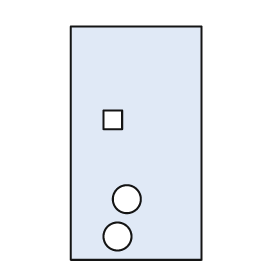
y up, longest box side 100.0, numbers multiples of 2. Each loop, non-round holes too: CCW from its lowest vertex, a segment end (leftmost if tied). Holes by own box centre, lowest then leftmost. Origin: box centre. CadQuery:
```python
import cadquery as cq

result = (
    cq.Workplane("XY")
    .moveTo(-28.0, -50.0)
    .lineTo(28.0, -50.0)
    .lineTo(28.0, 50.0)
    .lineTo(-28.0, 50.0)
    .close()
    .moveTo(-8.0, -40.0)
    .circle(6.0)
    .moveTo(-4.0, -24.0)
    .circle(6.0)
    .moveTo(-14.0, 6.0)
    .lineTo(-6.0, 6.0)
    .lineTo(-6.0, 14.0)
    .lineTo(-14.0, 14.0)
    .close()
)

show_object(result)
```